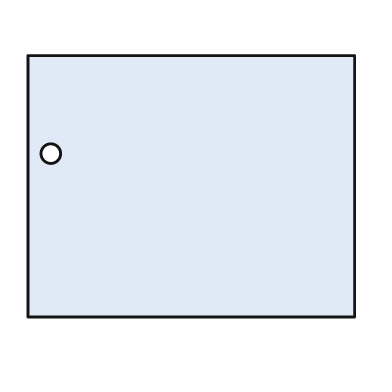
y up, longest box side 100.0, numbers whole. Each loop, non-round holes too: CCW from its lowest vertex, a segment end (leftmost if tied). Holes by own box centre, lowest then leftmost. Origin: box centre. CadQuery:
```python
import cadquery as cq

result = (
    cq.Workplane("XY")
    .moveTo(-50.0, -40.0)
    .lineTo(50.0, -40.0)
    .lineTo(50.0, 40.0)
    .lineTo(-50.0, 40.0)
    .close()
    .moveTo(-43.0, 10.0)
    .circle(3.0)
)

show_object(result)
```